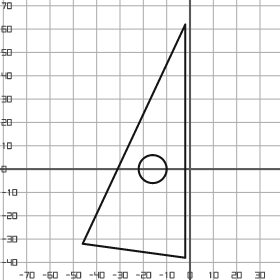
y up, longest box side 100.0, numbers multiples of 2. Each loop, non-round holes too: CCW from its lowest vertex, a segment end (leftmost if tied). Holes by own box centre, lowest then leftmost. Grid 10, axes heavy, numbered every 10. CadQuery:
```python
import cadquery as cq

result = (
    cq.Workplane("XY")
    .moveTo(-2.0, -38.0)
    .lineTo(-2.0, 62.0)
    .lineTo(-46.0, -32.0)
    .close()
    .moveTo(-16.0, 0.0)
    .circle(6.0)
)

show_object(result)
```